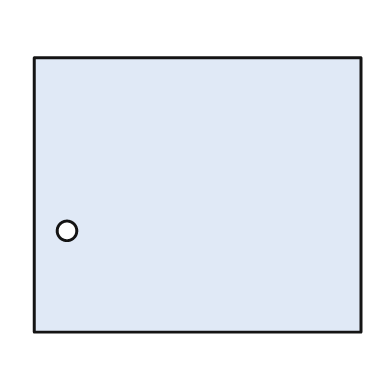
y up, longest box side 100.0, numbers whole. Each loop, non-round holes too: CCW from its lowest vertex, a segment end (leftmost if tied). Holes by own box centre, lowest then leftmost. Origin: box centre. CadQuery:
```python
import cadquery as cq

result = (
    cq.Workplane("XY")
    .moveTo(-50.0, -42.0)
    .lineTo(50.0, -42.0)
    .lineTo(50.0, 42.0)
    .lineTo(-50.0, 42.0)
    .close()
    .moveTo(-40.0, -11.0)
    .circle(3.0)
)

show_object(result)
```